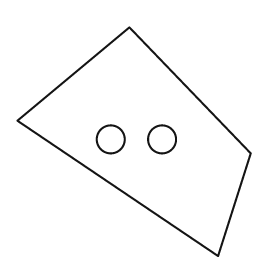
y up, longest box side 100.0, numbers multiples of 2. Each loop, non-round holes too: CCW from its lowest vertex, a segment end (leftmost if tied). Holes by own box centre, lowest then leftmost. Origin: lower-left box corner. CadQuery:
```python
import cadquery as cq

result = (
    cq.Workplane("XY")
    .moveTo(86.0, 0.0)
    .lineTo(100.0, 44.0)
    .lineTo(48.0, 98.0)
    .lineTo(0.0, 58.0)
    .close()
    .moveTo(40.0, 50.0)
    .circle(6.0)
    .moveTo(62.0, 50.0)
    .circle(6.0)
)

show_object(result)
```